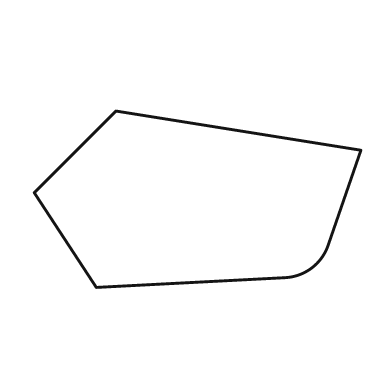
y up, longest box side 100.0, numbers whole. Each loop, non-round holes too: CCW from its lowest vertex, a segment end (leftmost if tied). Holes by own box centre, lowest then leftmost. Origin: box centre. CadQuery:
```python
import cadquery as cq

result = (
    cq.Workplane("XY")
    .moveTo(-31.0, -27.0)
    .lineTo(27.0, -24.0)
    .threePointArc((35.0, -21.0), (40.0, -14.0))
    .lineTo(50.0, 15.0)
    .lineTo(-25.0, 27.0)
    .lineTo(-50.0, 2.0)
    .close()
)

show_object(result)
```